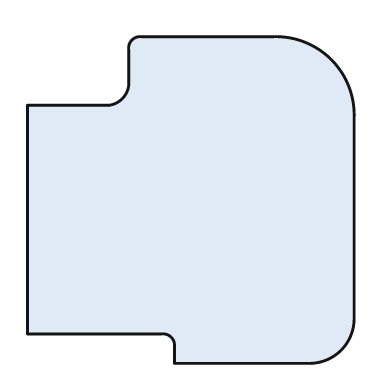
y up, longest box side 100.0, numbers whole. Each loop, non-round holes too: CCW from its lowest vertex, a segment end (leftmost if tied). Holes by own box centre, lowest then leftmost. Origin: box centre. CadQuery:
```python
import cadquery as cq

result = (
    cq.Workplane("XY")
    .moveTo(-5.0, -50.0)
    .lineTo(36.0, -50.0)
    .threePointArc((46.0, -46.0), (50.0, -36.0))
    .lineTo(50.0, 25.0)
    .threePointArc((43.0, 43.0), (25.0, 50.0))
    .lineTo(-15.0, 50.0)
    .threePointArc((-18.0, 49.0), (-19.0, 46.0))
    .lineTo(-19.0, 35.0)
    .threePointArc((-21.0, 31.0), (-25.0, 29.0))
    .lineTo(-50.0, 29.0)
    .lineTo(-50.0, -41.0)
    .lineTo(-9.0, -41.0)
    .threePointArc((-6.0, -42.0), (-5.0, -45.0))
    .close()
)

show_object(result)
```